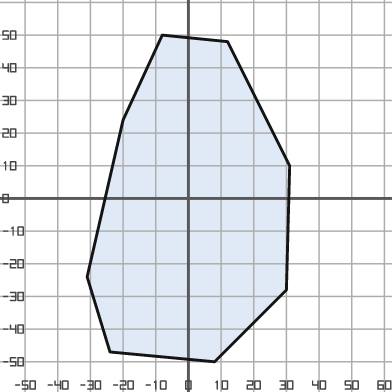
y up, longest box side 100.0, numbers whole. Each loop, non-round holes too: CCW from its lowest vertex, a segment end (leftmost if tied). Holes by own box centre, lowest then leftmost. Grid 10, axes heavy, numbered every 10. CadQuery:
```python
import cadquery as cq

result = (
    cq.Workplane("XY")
    .moveTo(8.0, -50.0)
    .lineTo(30.0, -28.0)
    .lineTo(31.0, 10.0)
    .lineTo(12.0, 48.0)
    .lineTo(-8.0, 50.0)
    .lineTo(-20.0, 24.0)
    .lineTo(-31.0, -24.0)
    .lineTo(-24.0, -47.0)
    .close()
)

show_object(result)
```